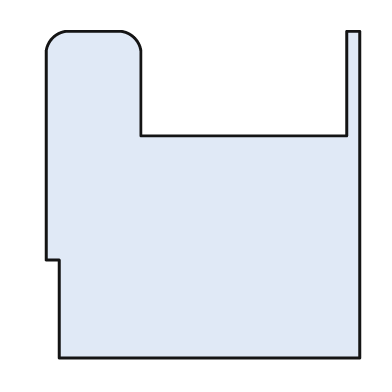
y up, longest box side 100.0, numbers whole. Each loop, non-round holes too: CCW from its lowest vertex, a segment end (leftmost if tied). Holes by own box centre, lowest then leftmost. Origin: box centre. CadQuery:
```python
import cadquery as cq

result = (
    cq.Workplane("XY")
    .moveTo(-44.0, -50.0)
    .lineTo(48.0, -50.0)
    .lineTo(48.0, 50.0)
    .lineTo(44.0, 50.0)
    .lineTo(44.0, 18.0)
    .lineTo(-19.0, 18.0)
    .lineTo(-19.0, 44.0)
    .threePointArc((-21.0, 48.0), (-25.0, 50.0))
    .lineTo(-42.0, 50.0)
    .threePointArc((-46.0, 48.0), (-48.0, 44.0))
    .lineTo(-48.0, -20.0)
    .lineTo(-44.0, -20.0)
    .close()
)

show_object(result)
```